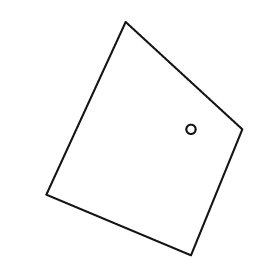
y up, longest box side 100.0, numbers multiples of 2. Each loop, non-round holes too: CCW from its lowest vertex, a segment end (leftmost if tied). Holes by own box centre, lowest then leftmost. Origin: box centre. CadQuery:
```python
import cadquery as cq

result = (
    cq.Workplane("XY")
    .moveTo(20.0, -50.0)
    .lineTo(42.0, 4.0)
    .lineTo(-8.0, 50.0)
    .lineTo(-42.0, -24.0)
    .close()
    .moveTo(20.0, 4.0)
    .circle(2.0)
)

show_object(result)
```